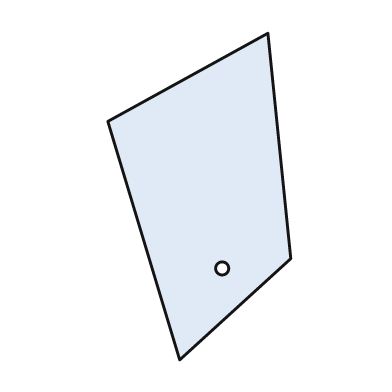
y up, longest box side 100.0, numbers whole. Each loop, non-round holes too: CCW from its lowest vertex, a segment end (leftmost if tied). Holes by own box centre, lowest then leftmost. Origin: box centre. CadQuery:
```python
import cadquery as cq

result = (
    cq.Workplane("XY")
    .moveTo(-6.0, -50.0)
    .lineTo(28.0, -19.0)
    .lineTo(21.0, 50.0)
    .lineTo(-28.0, 23.0)
    .close()
    .moveTo(7.0, -22.0)
    .circle(2.0)
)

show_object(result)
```